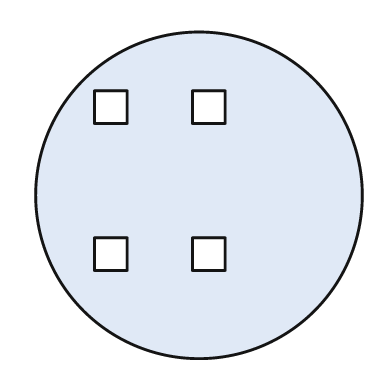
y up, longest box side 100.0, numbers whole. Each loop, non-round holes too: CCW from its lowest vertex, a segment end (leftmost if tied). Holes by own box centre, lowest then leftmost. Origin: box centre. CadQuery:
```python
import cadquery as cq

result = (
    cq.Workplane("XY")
    .moveTo(0.0, 0.0)
    .circle(50.0)
    .moveTo(-32.0, -23.0)
    .lineTo(-22.0, -23.0)
    .lineTo(-22.0, -13.0)
    .lineTo(-32.0, -13.0)
    .close()
    .moveTo(-2.0, -23.0)
    .lineTo(8.0, -23.0)
    .lineTo(8.0, -13.0)
    .lineTo(-2.0, -13.0)
    .close()
    .moveTo(-32.0, 22.0)
    .lineTo(-22.0, 22.0)
    .lineTo(-22.0, 32.0)
    .lineTo(-32.0, 32.0)
    .close()
    .moveTo(-2.0, 22.0)
    .lineTo(8.0, 22.0)
    .lineTo(8.0, 32.0)
    .lineTo(-2.0, 32.0)
    .close()
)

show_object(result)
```